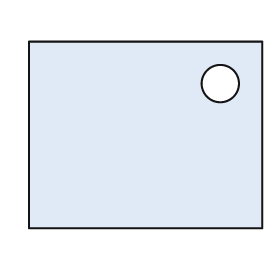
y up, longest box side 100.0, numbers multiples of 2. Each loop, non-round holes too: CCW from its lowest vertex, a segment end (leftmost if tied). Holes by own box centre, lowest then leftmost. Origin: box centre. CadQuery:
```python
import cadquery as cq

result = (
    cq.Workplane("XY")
    .moveTo(-50.0, -40.0)
    .lineTo(50.0, -40.0)
    .lineTo(50.0, 40.0)
    .lineTo(-50.0, 40.0)
    .close()
    .moveTo(32.0, 22.0)
    .circle(8.0)
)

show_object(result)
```